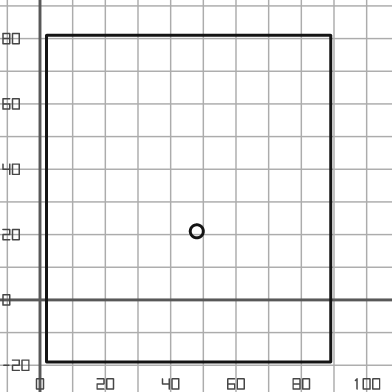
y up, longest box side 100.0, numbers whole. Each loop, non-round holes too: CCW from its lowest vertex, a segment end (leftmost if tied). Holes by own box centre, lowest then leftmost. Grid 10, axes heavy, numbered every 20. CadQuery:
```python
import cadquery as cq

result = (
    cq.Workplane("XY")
    .moveTo(2.0, -19.0)
    .lineTo(89.0, -19.0)
    .lineTo(89.0, 81.0)
    .lineTo(2.0, 81.0)
    .close()
    .moveTo(48.0, 21.0)
    .circle(2.0)
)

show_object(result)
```